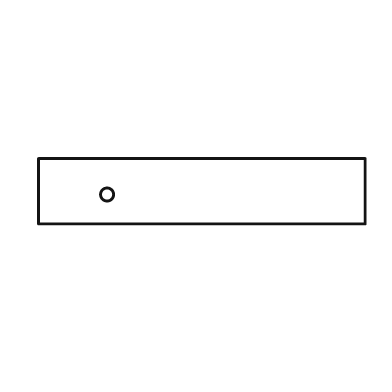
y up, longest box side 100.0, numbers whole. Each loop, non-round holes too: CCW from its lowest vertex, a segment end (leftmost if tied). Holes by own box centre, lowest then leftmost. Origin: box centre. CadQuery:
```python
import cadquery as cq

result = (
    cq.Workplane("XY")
    .moveTo(-50.0, -10.0)
    .lineTo(50.0, -10.0)
    .lineTo(50.0, 10.0)
    .lineTo(-50.0, 10.0)
    .close()
    .moveTo(-29.0, -1.0)
    .circle(2.0)
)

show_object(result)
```